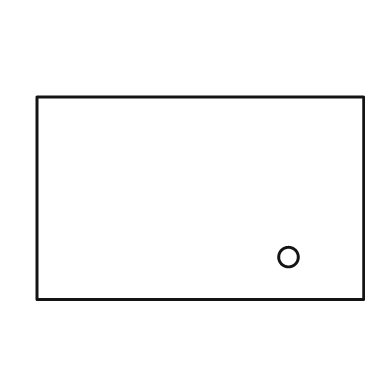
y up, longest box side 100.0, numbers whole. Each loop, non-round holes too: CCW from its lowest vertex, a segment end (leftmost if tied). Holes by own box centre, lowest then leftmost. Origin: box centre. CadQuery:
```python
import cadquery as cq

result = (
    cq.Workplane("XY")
    .moveTo(-50.0, -31.0)
    .lineTo(50.0, -31.0)
    .lineTo(50.0, 31.0)
    .lineTo(-50.0, 31.0)
    .close()
    .moveTo(27.0, -18.0)
    .circle(3.0)
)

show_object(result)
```